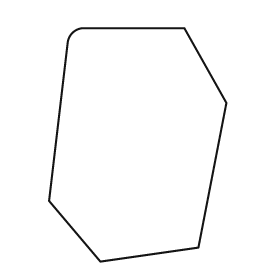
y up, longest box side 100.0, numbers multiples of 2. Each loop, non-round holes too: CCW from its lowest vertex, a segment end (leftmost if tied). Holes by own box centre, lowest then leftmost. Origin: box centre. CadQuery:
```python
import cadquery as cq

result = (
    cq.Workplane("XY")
    .moveTo(-16.0, -50.0)
    .lineTo(26.0, -44.0)
    .lineTo(38.0, 18.0)
    .lineTo(20.0, 50.0)
    .lineTo(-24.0, 50.0)
    .threePointArc((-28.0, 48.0), (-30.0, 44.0))
    .lineTo(-38.0, -24.0)
    .close()
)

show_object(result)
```